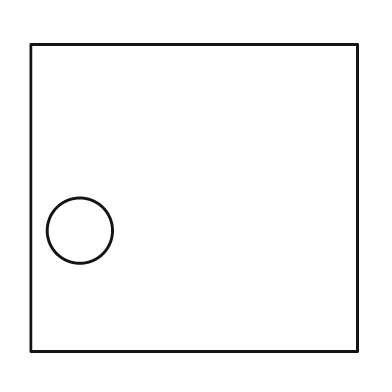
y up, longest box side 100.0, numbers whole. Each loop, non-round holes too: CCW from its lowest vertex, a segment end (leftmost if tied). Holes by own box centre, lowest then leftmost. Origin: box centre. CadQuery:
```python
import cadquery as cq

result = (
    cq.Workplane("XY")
    .moveTo(-50.0, -47.0)
    .lineTo(50.0, -47.0)
    .lineTo(50.0, 47.0)
    .lineTo(-50.0, 47.0)
    .close()
    .moveTo(-35.0, -10.0)
    .circle(10.0)
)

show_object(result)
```